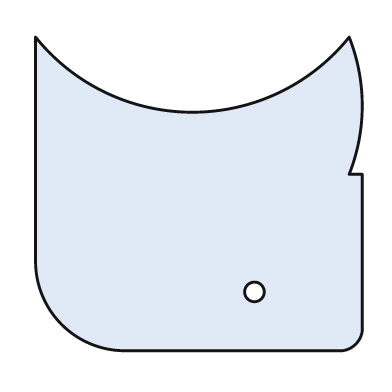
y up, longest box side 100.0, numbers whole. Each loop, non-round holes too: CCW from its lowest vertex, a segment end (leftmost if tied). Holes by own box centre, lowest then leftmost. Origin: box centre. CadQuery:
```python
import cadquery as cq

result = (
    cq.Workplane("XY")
    .moveTo(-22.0, -48.0)
    .lineTo(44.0, -48.0)
    .threePointArc((48.0, -46.0), (50.0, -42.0))
    .lineTo(50.0, 6.0)
    .lineTo(46.0, 6.0)
    .threePointArc((50.0, 27.0), (46.0, 48.0))
    .threePointArc((-2.0, 25.0), (-50.0, 48.0))
    .lineTo(-50.0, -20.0)
    .threePointArc((-42.0, -40.0), (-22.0, -48.0))
    .close()
    .moveTo(17.0, -30.0)
    .circle(3.0)
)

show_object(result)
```